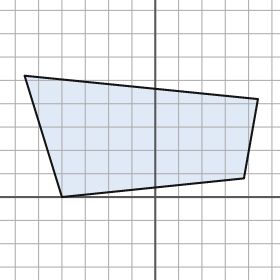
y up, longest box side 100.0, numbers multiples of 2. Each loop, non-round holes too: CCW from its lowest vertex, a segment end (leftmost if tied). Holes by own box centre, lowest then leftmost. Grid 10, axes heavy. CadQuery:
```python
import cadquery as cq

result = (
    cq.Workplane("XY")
    .moveTo(-40.0, 0.0)
    .lineTo(38.0, 8.0)
    .lineTo(44.0, 42.0)
    .lineTo(-56.0, 52.0)
    .close()
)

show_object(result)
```